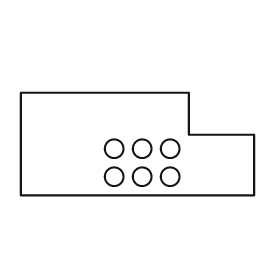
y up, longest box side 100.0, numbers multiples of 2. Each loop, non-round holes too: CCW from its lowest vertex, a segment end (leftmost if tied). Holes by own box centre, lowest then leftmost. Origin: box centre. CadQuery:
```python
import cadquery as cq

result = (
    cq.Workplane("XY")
    .moveTo(-50.0, -22.0)
    .lineTo(50.0, -22.0)
    .lineTo(50.0, 4.0)
    .lineTo(22.0, 4.0)
    .lineTo(22.0, 22.0)
    .lineTo(-50.0, 22.0)
    .close()
    .moveTo(-10.0, -14.0)
    .circle(4.0)
    .moveTo(2.0, -14.0)
    .circle(4.0)
    .moveTo(14.0, -14.0)
    .circle(4.0)
    .moveTo(-10.0, -2.0)
    .circle(4.0)
    .moveTo(2.0, -2.0)
    .circle(4.0)
    .moveTo(14.0, -2.0)
    .circle(4.0)
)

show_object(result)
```